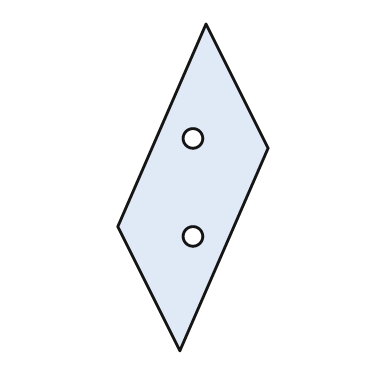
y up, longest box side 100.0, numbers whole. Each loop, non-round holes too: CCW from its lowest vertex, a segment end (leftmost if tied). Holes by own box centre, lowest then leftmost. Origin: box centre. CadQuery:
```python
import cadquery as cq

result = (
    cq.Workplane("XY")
    .moveTo(-4.0, -50.0)
    .lineTo(23.0, 12.0)
    .lineTo(4.0, 50.0)
    .lineTo(-23.0, -12.0)
    .close()
    .moveTo(0.0, -15.0)
    .circle(3.0)
    .moveTo(0.0, 15.0)
    .circle(3.0)
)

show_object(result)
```